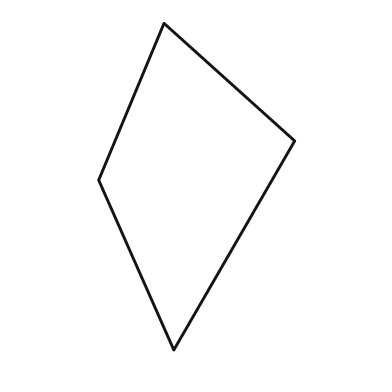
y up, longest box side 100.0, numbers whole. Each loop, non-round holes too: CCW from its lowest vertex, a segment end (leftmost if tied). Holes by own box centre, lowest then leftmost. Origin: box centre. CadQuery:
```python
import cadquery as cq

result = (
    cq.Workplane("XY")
    .moveTo(-7.0, -50.0)
    .lineTo(30.0, 14.0)
    .lineTo(-10.0, 50.0)
    .lineTo(-30.0, 2.0)
    .close()
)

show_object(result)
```